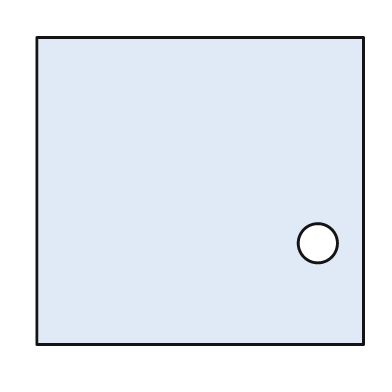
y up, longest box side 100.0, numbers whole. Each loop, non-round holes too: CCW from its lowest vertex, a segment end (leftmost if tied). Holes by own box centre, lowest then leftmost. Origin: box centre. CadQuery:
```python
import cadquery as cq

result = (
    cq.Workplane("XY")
    .moveTo(-50.0, -47.0)
    .lineTo(50.0, -47.0)
    .lineTo(50.0, 47.0)
    .lineTo(-50.0, 47.0)
    .close()
    .moveTo(36.0, -16.0)
    .circle(6.0)
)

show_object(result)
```